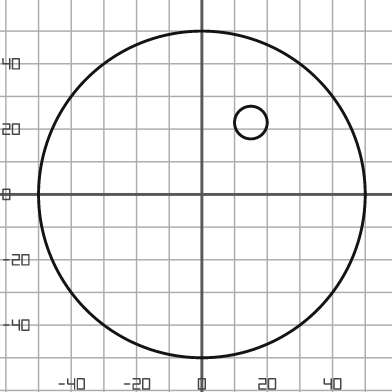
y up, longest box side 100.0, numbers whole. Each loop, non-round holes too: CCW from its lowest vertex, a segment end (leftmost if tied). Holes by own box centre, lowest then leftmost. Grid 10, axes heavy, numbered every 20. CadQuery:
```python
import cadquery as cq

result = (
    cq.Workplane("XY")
    .moveTo(0.0, 0.0)
    .circle(50.0)
    .moveTo(15.0, 22.0)
    .circle(5.0)
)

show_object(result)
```